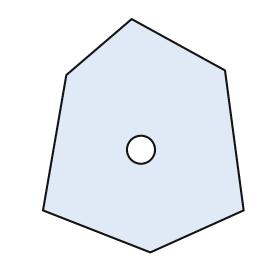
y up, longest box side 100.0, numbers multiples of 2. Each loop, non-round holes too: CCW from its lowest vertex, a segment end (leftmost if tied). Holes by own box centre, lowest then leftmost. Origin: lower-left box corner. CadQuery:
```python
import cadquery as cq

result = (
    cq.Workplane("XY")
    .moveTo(46.0, 0.0)
    .lineTo(86.0, 18.0)
    .lineTo(78.0, 78.0)
    .lineTo(38.0, 100.0)
    .lineTo(10.0, 76.0)
    .lineTo(0.0, 18.0)
    .close()
    .moveTo(42.0, 44.0)
    .circle(6.0)
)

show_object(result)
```